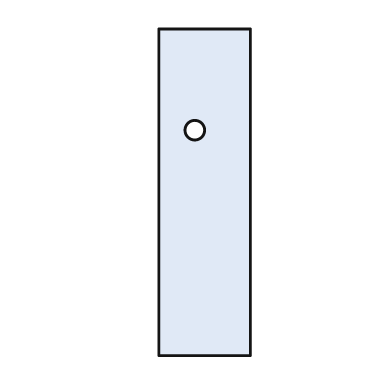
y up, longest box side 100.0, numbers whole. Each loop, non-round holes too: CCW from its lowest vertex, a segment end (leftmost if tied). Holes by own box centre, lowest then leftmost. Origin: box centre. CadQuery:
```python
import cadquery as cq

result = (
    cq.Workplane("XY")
    .moveTo(-14.0, -50.0)
    .lineTo(14.0, -50.0)
    .lineTo(14.0, 50.0)
    .lineTo(-14.0, 50.0)
    .close()
    .moveTo(-3.0, 19.0)
    .circle(3.0)
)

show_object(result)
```